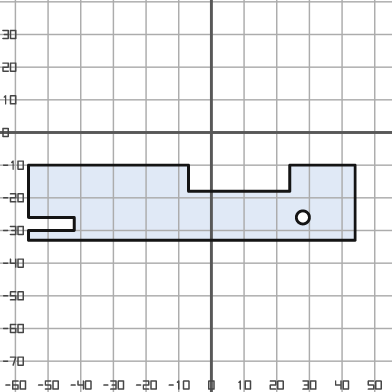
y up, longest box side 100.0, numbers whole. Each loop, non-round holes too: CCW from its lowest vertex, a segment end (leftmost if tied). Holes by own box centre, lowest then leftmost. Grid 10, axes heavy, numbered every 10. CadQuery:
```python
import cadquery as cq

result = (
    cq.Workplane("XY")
    .moveTo(-56.0, -33.0)
    .lineTo(44.0, -33.0)
    .lineTo(44.0, -10.0)
    .lineTo(24.0, -10.0)
    .lineTo(24.0, -18.0)
    .lineTo(-7.0, -18.0)
    .lineTo(-7.0, -10.0)
    .lineTo(-56.0, -10.0)
    .lineTo(-56.0, -26.0)
    .lineTo(-42.0, -26.0)
    .lineTo(-42.0, -30.0)
    .lineTo(-56.0, -30.0)
    .close()
    .moveTo(28.0, -26.0)
    .circle(2.0)
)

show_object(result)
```